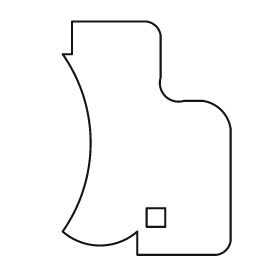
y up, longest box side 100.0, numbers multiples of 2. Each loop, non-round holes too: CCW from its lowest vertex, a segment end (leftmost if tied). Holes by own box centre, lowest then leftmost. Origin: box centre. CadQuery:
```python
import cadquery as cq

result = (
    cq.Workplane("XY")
    .moveTo(-4.0, -50.0)
    .lineTo(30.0, -50.0)
    .threePointArc((34.0, -48.0), (36.0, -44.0))
    .lineTo(36.0, 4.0)
    .threePointArc((32.0, 12.0), (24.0, 16.0))
    .lineTo(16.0, 16.0)
    .threePointArc((8.0, 18.0), (6.0, 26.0))
    .lineTo(6.0, 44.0)
    .threePointArc((4.0, 48.0), (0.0, 50.0))
    .lineTo(-32.0, 50.0)
    .lineTo(-32.0, 36.0)
    .lineTo(-36.0, 36.0)
    .threePointArc((-24.0, -2.0), (-36.0, -40.0))
    .threePointArc((-20.0, -46.0), (-4.0, -40.0))
    .close()
    .moveTo(0.0, -38.0)
    .lineTo(8.0, -38.0)
    .lineTo(8.0, -30.0)
    .lineTo(0.0, -30.0)
    .close()
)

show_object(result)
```